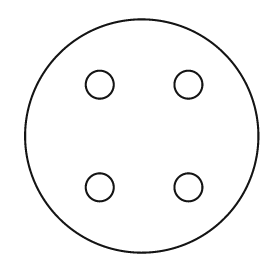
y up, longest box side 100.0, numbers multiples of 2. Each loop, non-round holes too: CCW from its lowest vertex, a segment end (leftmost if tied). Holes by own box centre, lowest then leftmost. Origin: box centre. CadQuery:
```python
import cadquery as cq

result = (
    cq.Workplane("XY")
    .moveTo(0.0, 0.0)
    .circle(50.0)
    .moveTo(-18.0, -22.0)
    .circle(6.0)
    .moveTo(20.0, -22.0)
    .circle(6.0)
    .moveTo(-18.0, 22.0)
    .circle(6.0)
    .moveTo(20.0, 22.0)
    .circle(6.0)
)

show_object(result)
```